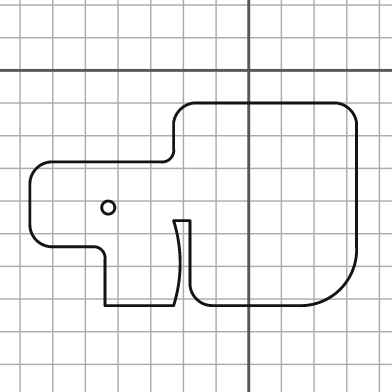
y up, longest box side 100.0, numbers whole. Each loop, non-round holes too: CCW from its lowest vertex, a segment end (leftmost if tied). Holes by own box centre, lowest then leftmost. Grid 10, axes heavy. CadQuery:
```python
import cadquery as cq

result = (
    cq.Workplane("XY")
    .moveTo(-44.0, -72.0)
    .lineTo(-23.0, -72.0)
    .threePointArc((-21.0, -59.0), (-23.0, -46.0))
    .lineTo(-18.0, -46.0)
    .lineTo(-18.0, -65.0)
    .threePointArc((-16.0, -70.0), (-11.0, -72.0))
    .lineTo(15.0, -72.0)
    .threePointArc((28.0, -67.0), (33.0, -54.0))
    .lineTo(33.0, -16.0)
    .threePointArc((31.0, -12.0), (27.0, -10.0))
    .lineTo(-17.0, -10.0)
    .threePointArc((-21.0, -12.0), (-23.0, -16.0))
    .lineTo(-23.0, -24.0)
    .threePointArc((-24.0, -27.0), (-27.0, -28.0))
    .lineTo(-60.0, -28.0)
    .threePointArc((-65.0, -30.0), (-67.0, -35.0))
    .lineTo(-67.0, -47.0)
    .threePointArc((-65.0, -52.0), (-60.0, -54.0))
    .lineTo(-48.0, -54.0)
    .threePointArc((-45.0, -55.0), (-44.0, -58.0))
    .close()
    .moveTo(-43.0, -42.0)
    .circle(2.0)
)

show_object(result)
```